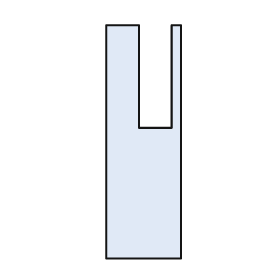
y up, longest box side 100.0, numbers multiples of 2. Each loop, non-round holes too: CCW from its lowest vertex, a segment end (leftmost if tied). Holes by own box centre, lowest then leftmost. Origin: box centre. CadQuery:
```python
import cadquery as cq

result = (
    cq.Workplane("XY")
    .moveTo(-16.0, -50.0)
    .lineTo(16.0, -50.0)
    .lineTo(16.0, 50.0)
    .lineTo(12.0, 50.0)
    .lineTo(12.0, 6.0)
    .lineTo(-2.0, 6.0)
    .lineTo(-2.0, 50.0)
    .lineTo(-16.0, 50.0)
    .close()
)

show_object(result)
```